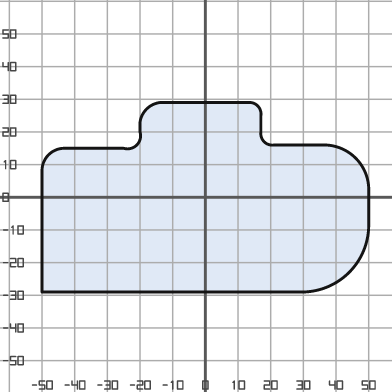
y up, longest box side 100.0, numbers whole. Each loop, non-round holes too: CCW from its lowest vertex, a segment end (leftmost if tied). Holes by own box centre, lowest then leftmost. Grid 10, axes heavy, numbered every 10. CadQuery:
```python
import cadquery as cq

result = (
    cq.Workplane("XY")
    .moveTo(-50.0, -29.0)
    .lineTo(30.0, -29.0)
    .threePointArc((44.0, -23.0), (50.0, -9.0))
    .lineTo(50.0, 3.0)
    .threePointArc((46.0, 12.0), (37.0, 16.0))
    .lineTo(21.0, 16.0)
    .threePointArc((18.0, 17.0), (17.0, 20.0))
    .lineTo(17.0, 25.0)
    .threePointArc((16.0, 28.0), (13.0, 29.0))
    .lineTo(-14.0, 29.0)
    .threePointArc((-18.0, 27.0), (-20.0, 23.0))
    .lineTo(-20.0, 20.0)
    .threePointArc((-21.0, 16.0), (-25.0, 15.0))
    .lineTo(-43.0, 15.0)
    .threePointArc((-48.0, 13.0), (-50.0, 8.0))
    .close()
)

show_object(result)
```